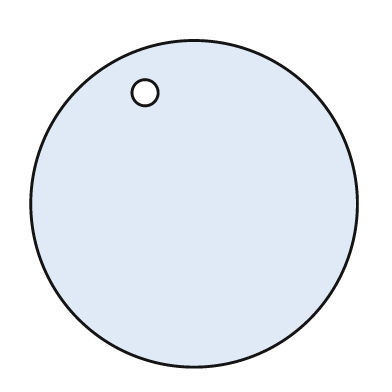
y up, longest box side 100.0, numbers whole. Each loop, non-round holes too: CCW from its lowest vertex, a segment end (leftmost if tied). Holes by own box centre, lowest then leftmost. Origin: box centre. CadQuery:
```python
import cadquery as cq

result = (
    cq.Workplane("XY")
    .moveTo(0.0, 0.0)
    .circle(50.0)
    .moveTo(-15.0, 34.0)
    .circle(4.0)
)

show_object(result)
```